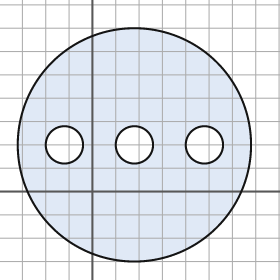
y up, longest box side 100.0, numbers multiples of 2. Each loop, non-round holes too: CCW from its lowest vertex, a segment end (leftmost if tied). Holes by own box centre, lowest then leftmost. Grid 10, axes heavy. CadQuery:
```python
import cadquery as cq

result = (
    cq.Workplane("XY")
    .moveTo(18.0, 20.0)
    .circle(50.0)
    .moveTo(-12.0, 20.0)
    .circle(8.0)
    .moveTo(18.0, 20.0)
    .circle(8.0)
    .moveTo(48.0, 20.0)
    .circle(8.0)
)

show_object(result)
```